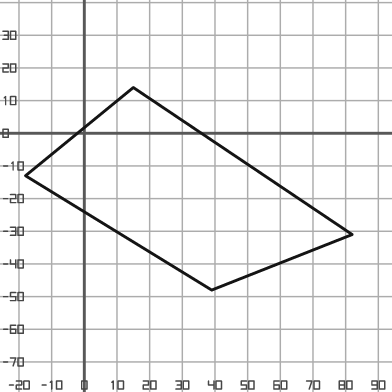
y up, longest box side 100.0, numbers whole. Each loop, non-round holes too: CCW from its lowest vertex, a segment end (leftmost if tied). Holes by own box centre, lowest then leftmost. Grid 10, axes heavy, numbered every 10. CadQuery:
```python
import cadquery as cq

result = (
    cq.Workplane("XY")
    .moveTo(39.0, -48.0)
    .lineTo(82.0, -31.0)
    .lineTo(15.0, 14.0)
    .lineTo(-18.0, -13.0)
    .close()
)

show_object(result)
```